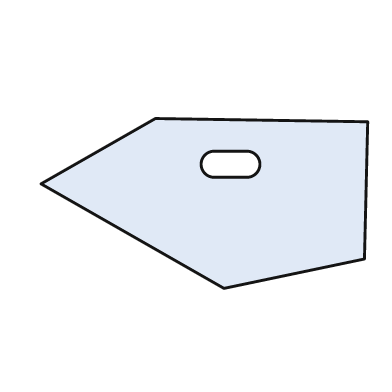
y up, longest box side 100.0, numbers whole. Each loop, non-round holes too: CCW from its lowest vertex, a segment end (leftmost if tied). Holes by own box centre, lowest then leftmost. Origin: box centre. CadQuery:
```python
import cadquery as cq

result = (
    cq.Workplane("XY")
    .moveTo(6.0, -26.0)
    .lineTo(49.0, -17.0)
    .lineTo(50.0, 25.0)
    .lineTo(-15.0, 26.0)
    .lineTo(-50.0, 6.0)
    .close()
    .moveTo(3.0, 8.0)
    .lineTo(13.0, 8.0)
    .threePointArc((17.0, 12.0), (13.0, 16.0))
    .lineTo(3.0, 16.0)
    .threePointArc((-1.0, 12.0), (3.0, 8.0))
    .close()
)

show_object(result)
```